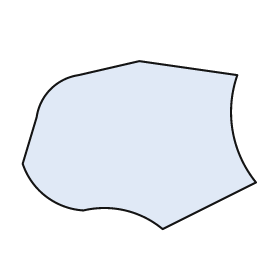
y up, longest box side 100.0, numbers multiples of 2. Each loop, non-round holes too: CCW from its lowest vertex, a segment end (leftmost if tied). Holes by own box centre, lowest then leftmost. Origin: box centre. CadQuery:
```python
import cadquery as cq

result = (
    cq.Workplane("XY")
    .moveTo(10.0, -36.0)
    .lineTo(50.0, -16.0)
    .threePointArc((40.0, 6.0), (42.0, 30.0))
    .lineTo(0.0, 36.0)
    .lineTo(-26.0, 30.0)
    .threePointArc((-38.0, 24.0), (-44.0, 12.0))
    .lineTo(-50.0, -8.0)
    .threePointArc((-40.0, -22.0), (-24.0, -28.0))
    .threePointArc((-6.0, -28.0), (10.0, -36.0))
    .close()
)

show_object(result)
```